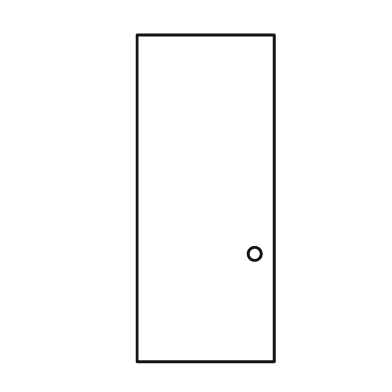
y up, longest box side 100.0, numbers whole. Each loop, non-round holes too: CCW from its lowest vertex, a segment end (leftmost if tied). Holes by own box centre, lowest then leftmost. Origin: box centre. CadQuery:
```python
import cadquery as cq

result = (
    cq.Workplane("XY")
    .moveTo(-21.0, -50.0)
    .lineTo(21.0, -50.0)
    .lineTo(21.0, 50.0)
    .lineTo(-21.0, 50.0)
    .close()
    .moveTo(15.0, -17.0)
    .circle(2.0)
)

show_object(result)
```